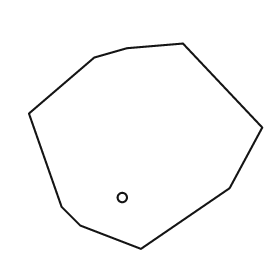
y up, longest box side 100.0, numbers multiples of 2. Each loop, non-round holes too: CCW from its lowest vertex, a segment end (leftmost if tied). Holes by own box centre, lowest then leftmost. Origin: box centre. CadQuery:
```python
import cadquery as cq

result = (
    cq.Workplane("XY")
    .moveTo(-2.0, -44.0)
    .lineTo(36.0, -18.0)
    .lineTo(50.0, 8.0)
    .lineTo(16.0, 44.0)
    .lineTo(-8.0, 42.0)
    .lineTo(-22.0, 38.0)
    .lineTo(-50.0, 14.0)
    .lineTo(-36.0, -26.0)
    .lineTo(-28.0, -34.0)
    .close()
    .moveTo(-10.0, -22.0)
    .circle(2.0)
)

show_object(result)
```